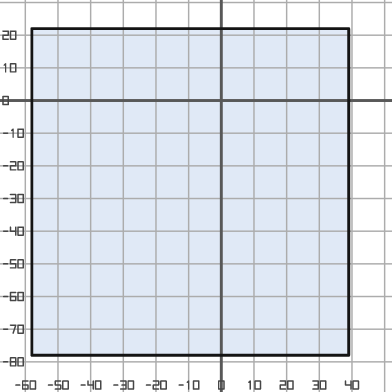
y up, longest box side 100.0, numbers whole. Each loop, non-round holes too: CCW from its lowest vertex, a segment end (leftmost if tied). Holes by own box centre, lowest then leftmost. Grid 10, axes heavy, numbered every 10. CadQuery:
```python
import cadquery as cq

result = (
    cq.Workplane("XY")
    .moveTo(-58.0, -78.0)
    .lineTo(39.0, -78.0)
    .lineTo(39.0, 22.0)
    .lineTo(-58.0, 22.0)
    .close()
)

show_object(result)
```